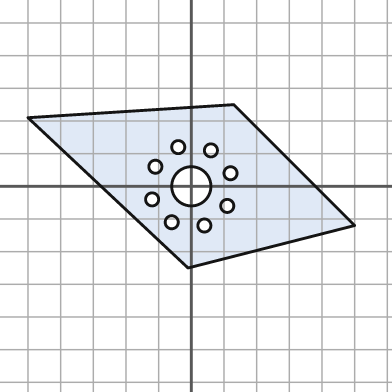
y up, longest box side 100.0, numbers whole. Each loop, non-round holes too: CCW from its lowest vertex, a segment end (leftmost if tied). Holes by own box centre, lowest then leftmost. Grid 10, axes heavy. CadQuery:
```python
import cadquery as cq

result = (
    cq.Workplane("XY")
    .moveTo(-1.0, -25.0)
    .lineTo(50.0, -12.0)
    .lineTo(13.0, 25.0)
    .lineTo(-50.0, 21.0)
    .close()
    .moveTo(4.0, -12.0)
    .circle(2.0)
    .moveTo(-6.0, -11.0)
    .circle(2.0)
    .moveTo(11.0, -6.0)
    .circle(2.0)
    .moveTo(-12.0, -4.0)
    .circle(2.0)
    .moveTo(0.0, 0.0)
    .circle(6.0)
    .moveTo(12.0, 4.0)
    .circle(2.0)
    .moveTo(-11.0, 6.0)
    .circle(2.0)
    .moveTo(6.0, 11.0)
    .circle(2.0)
    .moveTo(-4.0, 12.0)
    .circle(2.0)
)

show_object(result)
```